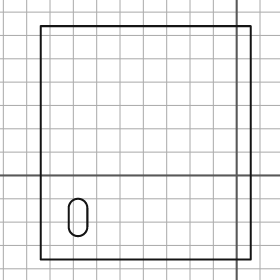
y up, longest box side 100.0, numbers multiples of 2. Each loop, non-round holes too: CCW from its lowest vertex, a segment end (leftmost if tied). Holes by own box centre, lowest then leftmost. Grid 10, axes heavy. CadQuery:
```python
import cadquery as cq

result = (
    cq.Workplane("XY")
    .moveTo(-84.0, -36.0)
    .lineTo(6.0, -36.0)
    .lineTo(6.0, 64.0)
    .lineTo(-84.0, 64.0)
    .close()
    .moveTo(-72.0, -22.0)
    .threePointArc((-68.0, -26.0), (-64.0, -22.0))
    .lineTo(-64.0, -14.0)
    .threePointArc((-68.0, -10.0), (-72.0, -14.0))
    .close()
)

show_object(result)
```